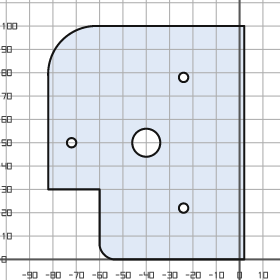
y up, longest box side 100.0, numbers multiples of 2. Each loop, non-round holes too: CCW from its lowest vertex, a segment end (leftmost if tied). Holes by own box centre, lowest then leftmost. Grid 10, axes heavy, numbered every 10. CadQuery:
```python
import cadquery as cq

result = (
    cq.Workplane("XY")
    .moveTo(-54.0, 0.0)
    .lineTo(2.0, 0.0)
    .lineTo(2.0, 100.0)
    .lineTo(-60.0, 100.0)
    .threePointArc((-76.0, 94.0), (-82.0, 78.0))
    .lineTo(-82.0, 30.0)
    .lineTo(-60.0, 30.0)
    .lineTo(-60.0, 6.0)
    .threePointArc((-58.0, 2.0), (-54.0, 0.0))
    .close()
    .moveTo(-24.0, 22.0)
    .circle(2.0)
    .moveTo(-72.0, 50.0)
    .circle(2.0)
    .moveTo(-40.0, 50.0)
    .circle(6.0)
    .moveTo(-24.0, 78.0)
    .circle(2.0)
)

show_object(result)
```